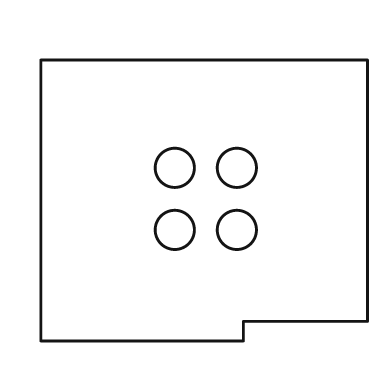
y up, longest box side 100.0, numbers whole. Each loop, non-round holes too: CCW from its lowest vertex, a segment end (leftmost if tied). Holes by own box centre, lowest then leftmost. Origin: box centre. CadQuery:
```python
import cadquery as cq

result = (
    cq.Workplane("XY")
    .moveTo(-50.0, -43.0)
    .lineTo(12.0, -43.0)
    .lineTo(12.0, -37.0)
    .lineTo(50.0, -37.0)
    .lineTo(50.0, 43.0)
    .lineTo(-50.0, 43.0)
    .close()
    .moveTo(-9.0, -9.0)
    .circle(6.0)
    .moveTo(10.0, -9.0)
    .circle(6.0)
    .moveTo(-9.0, 10.0)
    .circle(6.0)
    .moveTo(10.0, 10.0)
    .circle(6.0)
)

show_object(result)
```